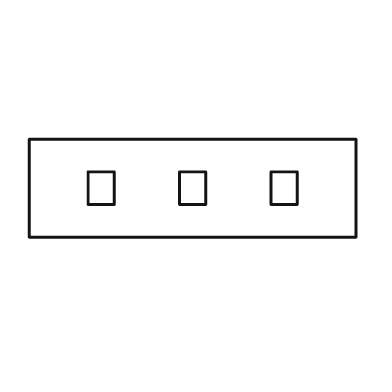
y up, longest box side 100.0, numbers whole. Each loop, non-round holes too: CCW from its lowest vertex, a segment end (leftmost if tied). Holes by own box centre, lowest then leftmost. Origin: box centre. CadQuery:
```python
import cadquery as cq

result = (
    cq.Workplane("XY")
    .moveTo(-50.0, -15.0)
    .lineTo(50.0, -15.0)
    .lineTo(50.0, 15.0)
    .lineTo(-50.0, 15.0)
    .close()
    .moveTo(-32.0, -5.0)
    .lineTo(-24.0, -5.0)
    .lineTo(-24.0, 5.0)
    .lineTo(-32.0, 5.0)
    .close()
    .moveTo(-4.0, -5.0)
    .lineTo(4.0, -5.0)
    .lineTo(4.0, 5.0)
    .lineTo(-4.0, 5.0)
    .close()
    .moveTo(24.0, -5.0)
    .lineTo(32.0, -5.0)
    .lineTo(32.0, 5.0)
    .lineTo(24.0, 5.0)
    .close()
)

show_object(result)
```